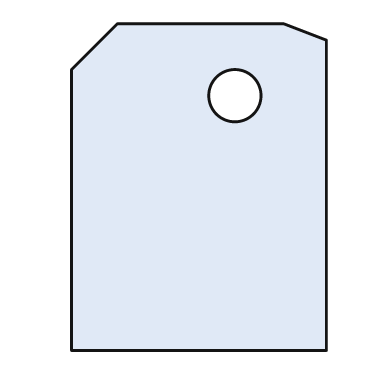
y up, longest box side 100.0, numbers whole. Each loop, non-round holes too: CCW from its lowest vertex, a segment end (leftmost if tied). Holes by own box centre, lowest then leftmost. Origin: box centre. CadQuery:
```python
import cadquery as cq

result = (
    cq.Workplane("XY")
    .moveTo(-39.0, -50.0)
    .lineTo(39.0, -50.0)
    .lineTo(39.0, 45.0)
    .lineTo(26.0, 50.0)
    .lineTo(-25.0, 50.0)
    .lineTo(-39.0, 36.0)
    .close()
    .moveTo(11.0, 28.0)
    .circle(8.0)
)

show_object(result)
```